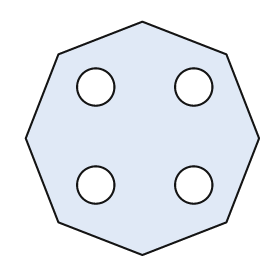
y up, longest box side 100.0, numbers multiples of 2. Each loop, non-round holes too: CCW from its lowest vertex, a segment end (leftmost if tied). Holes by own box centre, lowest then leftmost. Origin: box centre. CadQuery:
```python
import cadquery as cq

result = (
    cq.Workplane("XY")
    .moveTo(0.0, -50.0)
    .lineTo(36.0, -36.0)
    .lineTo(50.0, 0.0)
    .lineTo(36.0, 36.0)
    .lineTo(0.0, 50.0)
    .lineTo(-36.0, 36.0)
    .lineTo(-50.0, 0.0)
    .lineTo(-36.0, -36.0)
    .close()
    .moveTo(-20.0, -20.0)
    .circle(8.0)
    .moveTo(22.0, -20.0)
    .circle(8.0)
    .moveTo(-20.0, 22.0)
    .circle(8.0)
    .moveTo(22.0, 22.0)
    .circle(8.0)
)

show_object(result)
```